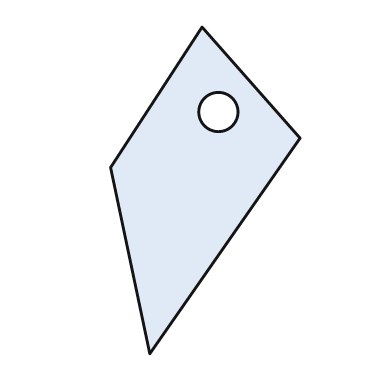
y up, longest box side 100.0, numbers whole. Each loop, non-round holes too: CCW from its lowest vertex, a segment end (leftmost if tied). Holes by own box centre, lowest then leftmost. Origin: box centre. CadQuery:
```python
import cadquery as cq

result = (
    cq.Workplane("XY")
    .moveTo(-17.0, -50.0)
    .lineTo(29.0, 16.0)
    .lineTo(-1.0, 50.0)
    .lineTo(-29.0, 7.0)
    .close()
    .moveTo(4.0, 24.0)
    .circle(6.0)
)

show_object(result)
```